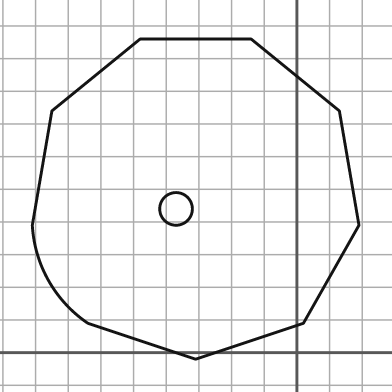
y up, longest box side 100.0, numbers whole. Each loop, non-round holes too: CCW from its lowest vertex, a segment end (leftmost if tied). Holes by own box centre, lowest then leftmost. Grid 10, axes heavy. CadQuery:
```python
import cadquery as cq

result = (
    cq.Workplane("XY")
    .moveTo(-31.0, -2.0)
    .lineTo(2.0, 9.0)
    .lineTo(19.0, 39.0)
    .lineTo(13.0, 74.0)
    .lineTo(-14.0, 96.0)
    .lineTo(-48.0, 96.0)
    .lineTo(-75.0, 74.0)
    .lineTo(-81.0, 39.0)
    .threePointArc((-76.0, 22.0), (-64.0, 9.0))
    .close()
    .moveTo(-37.0, 44.0)
    .circle(5.0)
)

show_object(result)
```